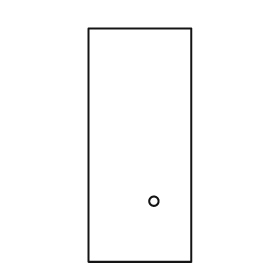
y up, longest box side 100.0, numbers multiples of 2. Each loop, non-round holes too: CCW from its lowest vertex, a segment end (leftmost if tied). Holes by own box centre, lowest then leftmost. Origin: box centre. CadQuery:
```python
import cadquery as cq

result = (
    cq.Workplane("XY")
    .moveTo(-22.0, -50.0)
    .lineTo(22.0, -50.0)
    .lineTo(22.0, 50.0)
    .lineTo(-22.0, 50.0)
    .close()
    .moveTo(6.0, -24.0)
    .circle(2.0)
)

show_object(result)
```